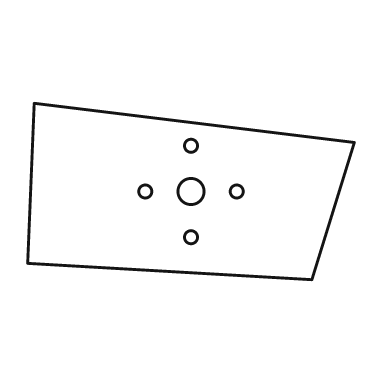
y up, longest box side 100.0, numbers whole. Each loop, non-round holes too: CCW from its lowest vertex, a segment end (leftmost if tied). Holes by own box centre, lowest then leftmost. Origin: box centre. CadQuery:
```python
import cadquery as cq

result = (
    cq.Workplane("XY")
    .moveTo(37.0, -27.0)
    .lineTo(50.0, 15.0)
    .lineTo(-48.0, 27.0)
    .lineTo(-50.0, -22.0)
    .close()
    .moveTo(0.0, -14.0)
    .circle(2.0)
    .moveTo(-14.0, 0.0)
    .circle(2.0)
    .moveTo(0.0, 0.0)
    .circle(4.0)
    .moveTo(14.0, 0.0)
    .circle(2.0)
    .moveTo(0.0, 14.0)
    .circle(2.0)
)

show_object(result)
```